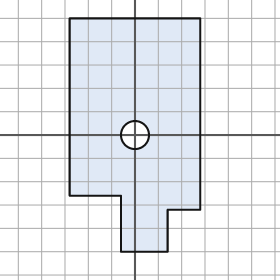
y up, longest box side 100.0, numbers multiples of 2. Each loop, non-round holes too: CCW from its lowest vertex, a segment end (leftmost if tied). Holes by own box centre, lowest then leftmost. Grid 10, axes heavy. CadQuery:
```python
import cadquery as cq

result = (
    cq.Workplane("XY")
    .moveTo(-6.0, -50.0)
    .lineTo(14.0, -50.0)
    .lineTo(14.0, -32.0)
    .lineTo(28.0, -32.0)
    .lineTo(28.0, 50.0)
    .lineTo(-28.0, 50.0)
    .lineTo(-28.0, -26.0)
    .lineTo(-6.0, -26.0)
    .close()
    .moveTo(0.0, 0.0)
    .circle(6.0)
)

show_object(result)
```